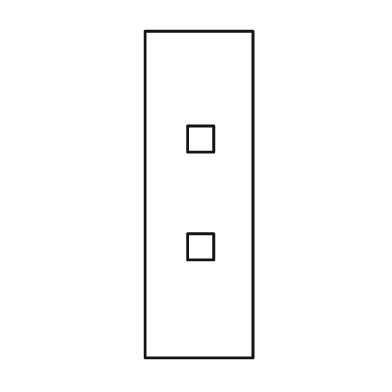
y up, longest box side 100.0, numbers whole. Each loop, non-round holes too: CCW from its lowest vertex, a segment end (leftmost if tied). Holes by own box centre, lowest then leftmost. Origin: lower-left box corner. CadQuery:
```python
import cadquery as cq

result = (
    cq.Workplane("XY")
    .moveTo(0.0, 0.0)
    .lineTo(33.0, 0.0)
    .lineTo(33.0, 100.0)
    .lineTo(0.0, 100.0)
    .close()
    .moveTo(13.0, 30.0)
    .lineTo(21.0, 30.0)
    .lineTo(21.0, 38.0)
    .lineTo(13.0, 38.0)
    .close()
    .moveTo(13.0, 63.0)
    .lineTo(21.0, 63.0)
    .lineTo(21.0, 71.0)
    .lineTo(13.0, 71.0)
    .close()
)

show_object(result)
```